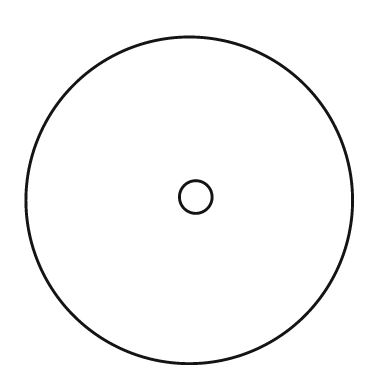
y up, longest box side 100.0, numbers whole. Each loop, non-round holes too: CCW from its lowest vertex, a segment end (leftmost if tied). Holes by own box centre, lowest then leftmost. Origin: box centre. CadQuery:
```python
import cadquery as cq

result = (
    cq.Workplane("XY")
    .moveTo(0.0, 0.0)
    .circle(50.0)
    .moveTo(2.0, 1.0)
    .circle(5.0)
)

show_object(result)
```